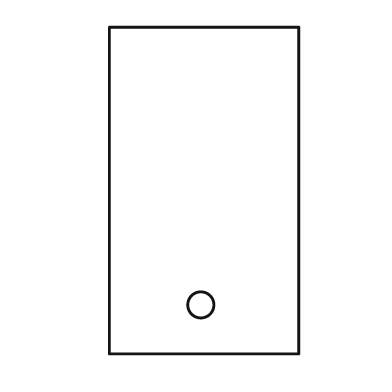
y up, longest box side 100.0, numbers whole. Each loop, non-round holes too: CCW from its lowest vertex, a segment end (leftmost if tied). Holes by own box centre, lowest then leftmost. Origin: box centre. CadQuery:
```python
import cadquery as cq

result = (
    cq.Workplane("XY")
    .moveTo(-29.0, -50.0)
    .lineTo(29.0, -50.0)
    .lineTo(29.0, 50.0)
    .lineTo(-29.0, 50.0)
    .close()
    .moveTo(-1.0, -35.0)
    .circle(4.0)
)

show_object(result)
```